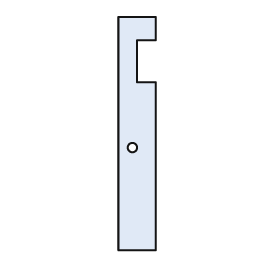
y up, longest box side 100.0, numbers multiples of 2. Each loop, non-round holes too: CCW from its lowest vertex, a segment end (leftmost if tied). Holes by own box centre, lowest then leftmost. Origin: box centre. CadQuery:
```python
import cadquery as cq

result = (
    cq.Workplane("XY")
    .moveTo(-8.0, -50.0)
    .lineTo(8.0, -50.0)
    .lineTo(8.0, 22.0)
    .lineTo(0.0, 22.0)
    .lineTo(0.0, 40.0)
    .lineTo(8.0, 40.0)
    .lineTo(8.0, 50.0)
    .lineTo(-8.0, 50.0)
    .close()
    .moveTo(-2.0, -6.0)
    .circle(2.0)
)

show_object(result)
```